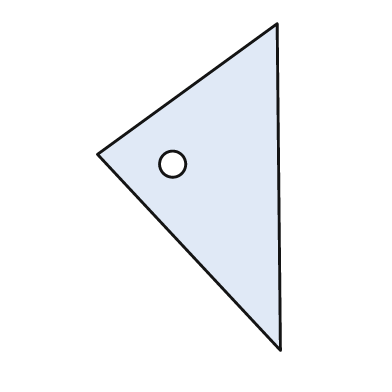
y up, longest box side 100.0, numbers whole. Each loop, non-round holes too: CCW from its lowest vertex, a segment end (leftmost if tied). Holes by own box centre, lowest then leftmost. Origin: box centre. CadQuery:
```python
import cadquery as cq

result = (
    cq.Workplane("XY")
    .moveTo(28.0, -50.0)
    .lineTo(27.0, 50.0)
    .lineTo(-28.0, 10.0)
    .close()
    .moveTo(-5.0, 7.0)
    .circle(4.0)
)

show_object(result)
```